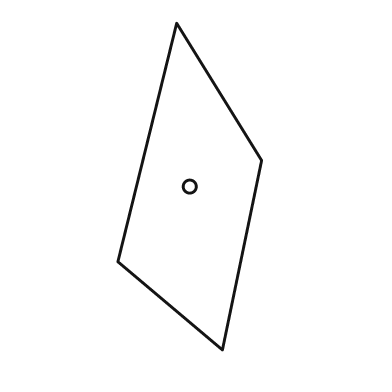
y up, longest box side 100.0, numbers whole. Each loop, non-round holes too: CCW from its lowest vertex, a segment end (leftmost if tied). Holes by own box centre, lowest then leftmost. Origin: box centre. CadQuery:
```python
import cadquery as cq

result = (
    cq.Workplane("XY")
    .moveTo(10.0, -50.0)
    .lineTo(22.0, 8.0)
    .lineTo(-4.0, 50.0)
    .lineTo(-22.0, -23.0)
    .close()
    .moveTo(0.0, 0.0)
    .circle(2.0)
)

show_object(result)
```